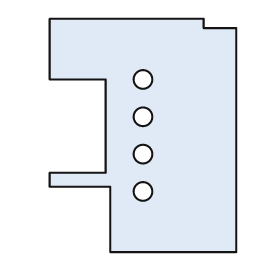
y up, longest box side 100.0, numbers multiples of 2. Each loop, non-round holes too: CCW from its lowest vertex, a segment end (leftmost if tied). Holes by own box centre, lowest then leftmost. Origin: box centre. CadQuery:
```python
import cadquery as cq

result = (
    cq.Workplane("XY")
    .moveTo(-14.0, -50.0)
    .lineTo(40.0, -50.0)
    .lineTo(40.0, 46.0)
    .lineTo(26.0, 46.0)
    .lineTo(26.0, 50.0)
    .lineTo(-40.0, 50.0)
    .lineTo(-40.0, 24.0)
    .lineTo(-16.0, 24.0)
    .lineTo(-16.0, -16.0)
    .lineTo(-40.0, -16.0)
    .lineTo(-40.0, -22.0)
    .lineTo(-14.0, -22.0)
    .close()
    .moveTo(0.0, -24.0)
    .circle(4.0)
    .moveTo(0.0, -8.0)
    .circle(4.0)
    .moveTo(0.0, 8.0)
    .circle(4.0)
    .moveTo(0.0, 24.0)
    .circle(4.0)
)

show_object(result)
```